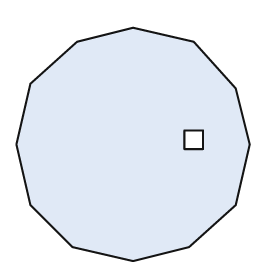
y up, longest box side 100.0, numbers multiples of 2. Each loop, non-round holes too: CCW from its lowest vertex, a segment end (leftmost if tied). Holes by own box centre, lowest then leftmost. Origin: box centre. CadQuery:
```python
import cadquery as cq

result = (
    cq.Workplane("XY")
    .moveTo(0.0, -50.0)
    .lineTo(24.0, -44.0)
    .lineTo(44.0, -26.0)
    .lineTo(50.0, 0.0)
    .lineTo(44.0, 24.0)
    .lineTo(26.0, 44.0)
    .lineTo(0.0, 50.0)
    .lineTo(-24.0, 44.0)
    .lineTo(-44.0, 26.0)
    .lineTo(-50.0, 0.0)
    .lineTo(-44.0, -26.0)
    .lineTo(-26.0, -44.0)
    .close()
    .moveTo(22.0, -2.0)
    .lineTo(30.0, -2.0)
    .lineTo(30.0, 6.0)
    .lineTo(22.0, 6.0)
    .close()
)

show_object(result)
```